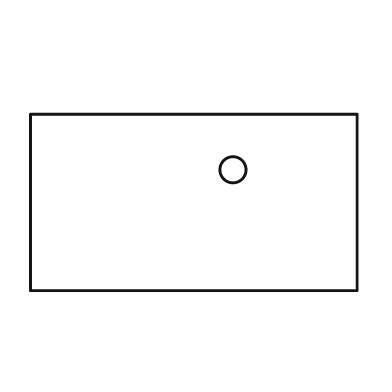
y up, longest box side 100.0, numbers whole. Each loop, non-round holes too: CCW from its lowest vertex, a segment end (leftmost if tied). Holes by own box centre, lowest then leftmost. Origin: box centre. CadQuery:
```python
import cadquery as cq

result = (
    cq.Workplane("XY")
    .moveTo(-50.0, -27.0)
    .lineTo(50.0, -27.0)
    .lineTo(50.0, 27.0)
    .lineTo(-50.0, 27.0)
    .close()
    .moveTo(12.0, 10.0)
    .circle(4.0)
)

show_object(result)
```